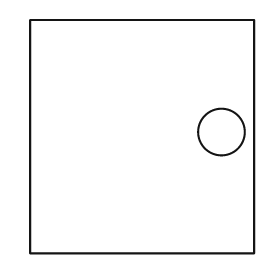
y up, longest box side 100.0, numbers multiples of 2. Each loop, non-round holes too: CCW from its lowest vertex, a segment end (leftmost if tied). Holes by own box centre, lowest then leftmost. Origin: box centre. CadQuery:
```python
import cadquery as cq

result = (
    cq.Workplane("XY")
    .moveTo(-48.0, -50.0)
    .lineTo(48.0, -50.0)
    .lineTo(48.0, 50.0)
    .lineTo(-48.0, 50.0)
    .close()
    .moveTo(34.0, 2.0)
    .circle(10.0)
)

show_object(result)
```